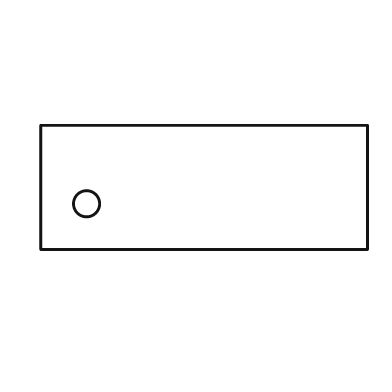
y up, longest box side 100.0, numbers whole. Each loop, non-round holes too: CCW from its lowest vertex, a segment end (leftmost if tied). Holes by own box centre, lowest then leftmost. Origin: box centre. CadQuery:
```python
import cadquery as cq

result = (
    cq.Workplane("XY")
    .moveTo(-50.0, -19.0)
    .lineTo(50.0, -19.0)
    .lineTo(50.0, 19.0)
    .lineTo(-50.0, 19.0)
    .close()
    .moveTo(-36.0, -5.0)
    .circle(4.0)
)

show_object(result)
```